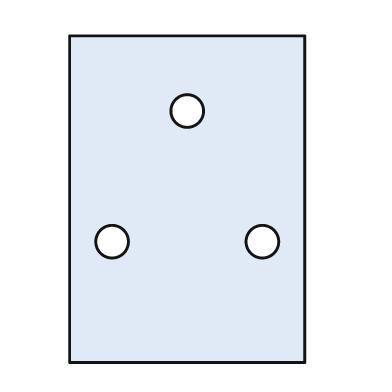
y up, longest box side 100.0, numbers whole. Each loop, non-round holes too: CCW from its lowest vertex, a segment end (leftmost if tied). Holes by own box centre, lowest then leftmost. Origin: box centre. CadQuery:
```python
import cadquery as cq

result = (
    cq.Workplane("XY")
    .moveTo(-36.0, -50.0)
    .lineTo(36.0, -50.0)
    .lineTo(36.0, 50.0)
    .lineTo(-36.0, 50.0)
    .close()
    .moveTo(-23.0, -13.0)
    .circle(5.0)
    .moveTo(23.0, -13.0)
    .circle(5.0)
    .moveTo(0.0, 27.0)
    .circle(5.0)
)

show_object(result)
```